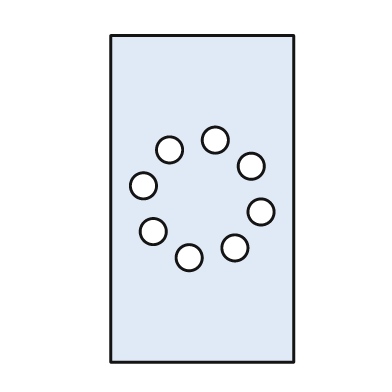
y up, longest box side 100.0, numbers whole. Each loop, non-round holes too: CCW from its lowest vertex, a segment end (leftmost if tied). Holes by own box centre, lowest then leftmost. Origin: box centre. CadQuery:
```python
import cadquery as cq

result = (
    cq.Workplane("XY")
    .moveTo(-28.0, -50.0)
    .lineTo(28.0, -50.0)
    .lineTo(28.0, 50.0)
    .lineTo(-28.0, 50.0)
    .close()
    .moveTo(-4.0, -18.0)
    .circle(4.0)
    .moveTo(10.0, -15.0)
    .circle(4.0)
    .moveTo(-15.0, -10.0)
    .circle(4.0)
    .moveTo(18.0, -4.0)
    .circle(4.0)
    .moveTo(-18.0, 4.0)
    .circle(4.0)
    .moveTo(15.0, 10.0)
    .circle(4.0)
    .moveTo(-10.0, 15.0)
    .circle(4.0)
    .moveTo(4.0, 18.0)
    .circle(4.0)
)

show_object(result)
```